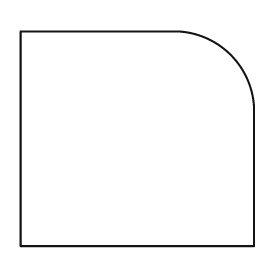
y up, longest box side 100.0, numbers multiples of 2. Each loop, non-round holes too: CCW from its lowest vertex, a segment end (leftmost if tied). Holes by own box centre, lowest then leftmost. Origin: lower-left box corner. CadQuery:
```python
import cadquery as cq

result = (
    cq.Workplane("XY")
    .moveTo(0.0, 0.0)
    .lineTo(100.0, 0.0)
    .lineTo(100.0, 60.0)
    .threePointArc((90.0, 82.0), (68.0, 92.0))
    .lineTo(0.0, 92.0)
    .close()
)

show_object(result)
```